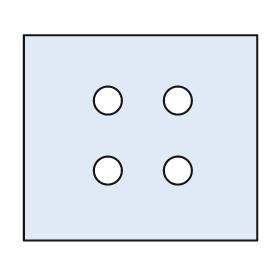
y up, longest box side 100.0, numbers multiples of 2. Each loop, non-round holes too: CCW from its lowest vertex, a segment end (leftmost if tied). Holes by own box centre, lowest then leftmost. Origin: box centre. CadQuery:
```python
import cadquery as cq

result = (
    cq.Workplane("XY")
    .moveTo(-50.0, -44.0)
    .lineTo(50.0, -44.0)
    .lineTo(50.0, 44.0)
    .lineTo(-50.0, 44.0)
    .close()
    .moveTo(-14.0, -14.0)
    .circle(6.0)
    .moveTo(16.0, -14.0)
    .circle(6.0)
    .moveTo(-14.0, 16.0)
    .circle(6.0)
    .moveTo(16.0, 16.0)
    .circle(6.0)
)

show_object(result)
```